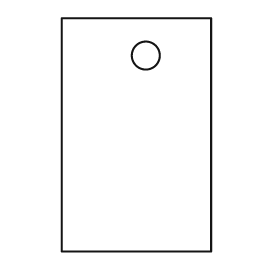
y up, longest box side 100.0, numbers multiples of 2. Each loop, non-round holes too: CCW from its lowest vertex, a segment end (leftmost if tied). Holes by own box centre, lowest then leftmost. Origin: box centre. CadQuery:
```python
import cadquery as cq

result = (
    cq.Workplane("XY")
    .moveTo(-32.0, -50.0)
    .lineTo(32.0, -50.0)
    .lineTo(32.0, 50.0)
    .lineTo(-32.0, 50.0)
    .close()
    .moveTo(4.0, 34.0)
    .circle(6.0)
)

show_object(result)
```